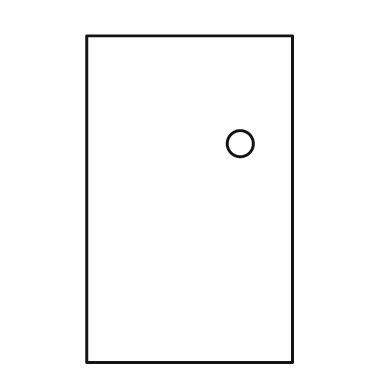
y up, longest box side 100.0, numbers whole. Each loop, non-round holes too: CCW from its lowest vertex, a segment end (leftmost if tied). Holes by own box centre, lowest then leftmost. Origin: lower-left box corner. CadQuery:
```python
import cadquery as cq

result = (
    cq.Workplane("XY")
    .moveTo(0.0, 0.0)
    .lineTo(63.0, 0.0)
    .lineTo(63.0, 100.0)
    .lineTo(0.0, 100.0)
    .close()
    .moveTo(47.0, 67.0)
    .circle(4.0)
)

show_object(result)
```